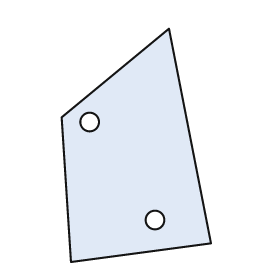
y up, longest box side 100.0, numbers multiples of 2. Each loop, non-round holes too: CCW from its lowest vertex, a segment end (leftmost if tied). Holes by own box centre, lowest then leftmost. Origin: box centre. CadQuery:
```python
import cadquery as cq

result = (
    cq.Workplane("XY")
    .moveTo(-28.0, -50.0)
    .lineTo(32.0, -42.0)
    .lineTo(14.0, 50.0)
    .lineTo(-32.0, 12.0)
    .close()
    .moveTo(8.0, -32.0)
    .circle(4.0)
    .moveTo(-20.0, 10.0)
    .circle(4.0)
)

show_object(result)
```